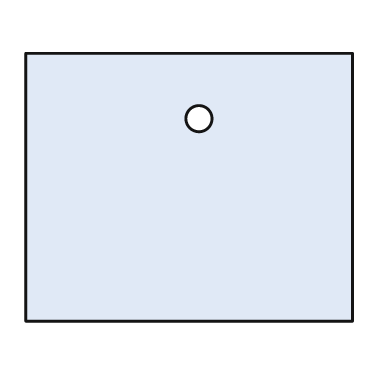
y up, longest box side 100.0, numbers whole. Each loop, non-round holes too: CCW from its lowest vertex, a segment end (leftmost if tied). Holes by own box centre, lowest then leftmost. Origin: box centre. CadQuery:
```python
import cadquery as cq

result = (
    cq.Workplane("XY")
    .moveTo(-50.0, -41.0)
    .lineTo(50.0, -41.0)
    .lineTo(50.0, 41.0)
    .lineTo(-50.0, 41.0)
    .close()
    .moveTo(3.0, 21.0)
    .circle(4.0)
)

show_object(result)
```